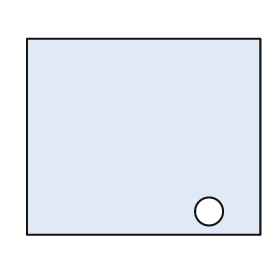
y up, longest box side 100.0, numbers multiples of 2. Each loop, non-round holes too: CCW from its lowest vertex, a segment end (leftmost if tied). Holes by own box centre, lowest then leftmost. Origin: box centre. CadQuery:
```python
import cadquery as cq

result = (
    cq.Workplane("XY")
    .moveTo(-50.0, -42.0)
    .lineTo(50.0, -42.0)
    .lineTo(50.0, 42.0)
    .lineTo(-50.0, 42.0)
    .close()
    .moveTo(28.0, -32.0)
    .circle(6.0)
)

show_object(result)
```